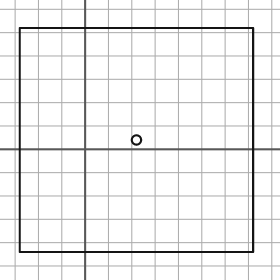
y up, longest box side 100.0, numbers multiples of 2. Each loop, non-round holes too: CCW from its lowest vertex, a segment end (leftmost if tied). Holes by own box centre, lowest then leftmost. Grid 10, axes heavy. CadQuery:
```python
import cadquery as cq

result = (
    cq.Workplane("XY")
    .moveTo(-28.0, -44.0)
    .lineTo(72.0, -44.0)
    .lineTo(72.0, 52.0)
    .lineTo(-28.0, 52.0)
    .close()
    .moveTo(22.0, 4.0)
    .circle(2.0)
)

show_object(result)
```